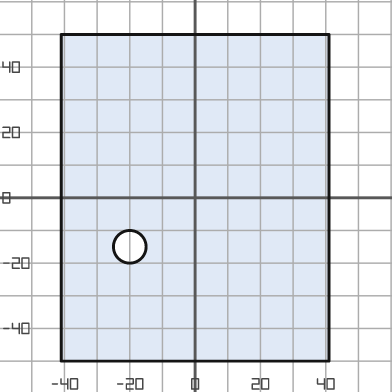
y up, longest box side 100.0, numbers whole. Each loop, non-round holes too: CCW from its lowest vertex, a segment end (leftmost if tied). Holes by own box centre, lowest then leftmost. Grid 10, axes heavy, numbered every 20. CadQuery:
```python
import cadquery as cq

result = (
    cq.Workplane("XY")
    .moveTo(-41.0, -50.0)
    .lineTo(41.0, -50.0)
    .lineTo(41.0, 50.0)
    .lineTo(-41.0, 50.0)
    .close()
    .moveTo(-20.0, -15.0)
    .circle(5.0)
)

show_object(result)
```